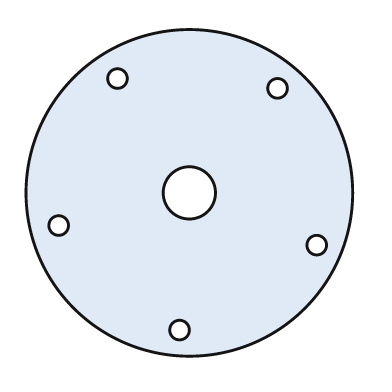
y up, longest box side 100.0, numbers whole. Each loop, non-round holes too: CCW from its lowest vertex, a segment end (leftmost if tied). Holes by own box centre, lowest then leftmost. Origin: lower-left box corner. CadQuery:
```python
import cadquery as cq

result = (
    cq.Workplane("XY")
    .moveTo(50.0, 50.0)
    .circle(50.0)
    .moveTo(47.0, 8.0)
    .circle(3.0)
    .moveTo(89.0, 34.0)
    .circle(3.0)
    .moveTo(10.0, 40.0)
    .circle(3.0)
    .moveTo(50.0, 50.0)
    .circle(8.0)
    .moveTo(77.0, 82.0)
    .circle(3.0)
    .moveTo(28.0, 85.0)
    .circle(3.0)
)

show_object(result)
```